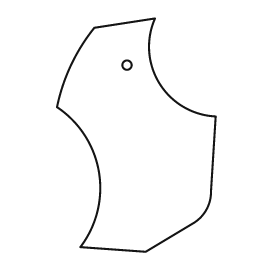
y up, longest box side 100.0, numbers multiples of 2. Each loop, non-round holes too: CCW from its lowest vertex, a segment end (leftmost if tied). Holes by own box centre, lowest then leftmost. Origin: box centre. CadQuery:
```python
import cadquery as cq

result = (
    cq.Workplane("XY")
    .moveTo(4.0, -50.0)
    .lineTo(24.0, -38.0)
    .threePointArc((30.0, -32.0), (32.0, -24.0))
    .lineTo(34.0, 8.0)
    .threePointArc((10.0, 22.0), (8.0, 50.0))
    .lineTo(-18.0, 46.0)
    .threePointArc((-28.0, 30.0), (-34.0, 12.0))
    .threePointArc((-16.0, -16.0), (-24.0, -48.0))
    .close()
    .moveTo(-4.0, 30.0)
    .circle(2.0)
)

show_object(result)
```